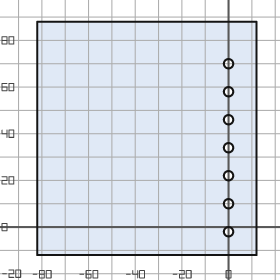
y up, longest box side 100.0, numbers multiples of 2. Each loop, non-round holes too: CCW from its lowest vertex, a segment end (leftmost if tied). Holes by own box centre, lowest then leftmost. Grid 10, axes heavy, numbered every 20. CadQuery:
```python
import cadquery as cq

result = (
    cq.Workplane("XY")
    .moveTo(-82.0, -12.0)
    .lineTo(12.0, -12.0)
    .lineTo(12.0, 88.0)
    .lineTo(-82.0, 88.0)
    .close()
    .moveTo(0.0, -2.0)
    .circle(2.0)
    .moveTo(0.0, 10.0)
    .circle(2.0)
    .moveTo(0.0, 22.0)
    .circle(2.0)
    .moveTo(0.0, 34.0)
    .circle(2.0)
    .moveTo(0.0, 46.0)
    .circle(2.0)
    .moveTo(0.0, 58.0)
    .circle(2.0)
    .moveTo(0.0, 70.0)
    .circle(2.0)
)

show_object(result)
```